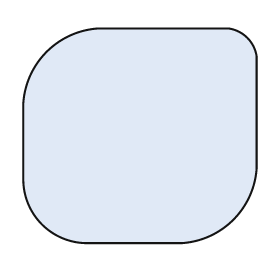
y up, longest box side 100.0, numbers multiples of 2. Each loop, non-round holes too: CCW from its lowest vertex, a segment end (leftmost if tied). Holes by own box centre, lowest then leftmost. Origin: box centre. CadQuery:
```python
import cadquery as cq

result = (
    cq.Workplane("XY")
    .moveTo(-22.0, -46.0)
    .lineTo(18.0, -46.0)
    .threePointArc((40.0, -36.0), (50.0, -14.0))
    .lineTo(50.0, 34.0)
    .threePointArc((46.0, 42.0), (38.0, 46.0))
    .lineTo(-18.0, 46.0)
    .threePointArc((-40.0, 36.0), (-50.0, 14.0))
    .lineTo(-50.0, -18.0)
    .threePointArc((-42.0, -38.0), (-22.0, -46.0))
    .close()
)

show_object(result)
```